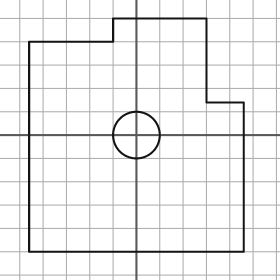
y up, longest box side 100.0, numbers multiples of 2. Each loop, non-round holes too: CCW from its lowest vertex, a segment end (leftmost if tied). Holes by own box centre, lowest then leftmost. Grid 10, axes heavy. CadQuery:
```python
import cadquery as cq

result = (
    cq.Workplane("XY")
    .moveTo(-46.0, -50.0)
    .lineTo(46.0, -50.0)
    .lineTo(46.0, 14.0)
    .lineTo(30.0, 14.0)
    .lineTo(30.0, 50.0)
    .lineTo(-10.0, 50.0)
    .lineTo(-10.0, 40.0)
    .lineTo(-46.0, 40.0)
    .close()
    .moveTo(0.0, 0.0)
    .circle(10.0)
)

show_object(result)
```